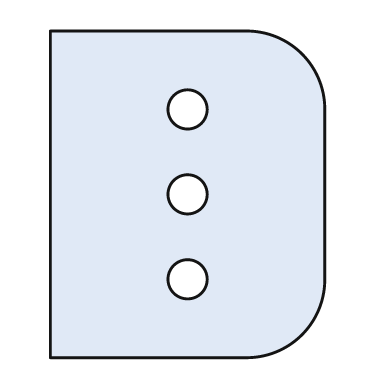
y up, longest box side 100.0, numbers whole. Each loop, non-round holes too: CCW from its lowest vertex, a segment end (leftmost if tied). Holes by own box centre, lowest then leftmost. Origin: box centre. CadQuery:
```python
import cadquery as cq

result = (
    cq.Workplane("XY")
    .moveTo(-42.0, -50.0)
    .lineTo(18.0, -50.0)
    .threePointArc((35.0, -43.0), (42.0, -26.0))
    .lineTo(42.0, 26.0)
    .threePointArc((35.0, 43.0), (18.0, 50.0))
    .lineTo(-42.0, 50.0)
    .close()
    .moveTo(0.0, -26.0)
    .circle(6.0)
    .moveTo(0.0, 0.0)
    .circle(6.0)
    .moveTo(0.0, 26.0)
    .circle(6.0)
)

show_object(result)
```